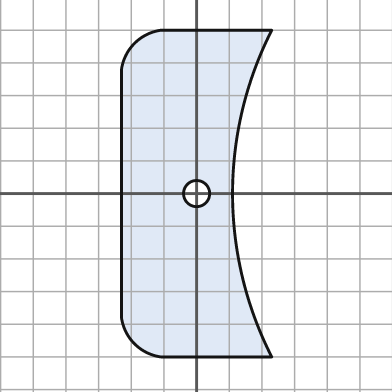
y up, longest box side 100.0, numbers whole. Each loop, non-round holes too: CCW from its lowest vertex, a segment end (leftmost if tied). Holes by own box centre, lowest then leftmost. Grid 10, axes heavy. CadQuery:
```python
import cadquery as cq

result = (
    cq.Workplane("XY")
    .moveTo(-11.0, -50.0)
    .lineTo(23.0, -50.0)
    .threePointArc((11.0, 0.0), (23.0, 50.0))
    .lineTo(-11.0, 50.0)
    .threePointArc((-19.0, 46.0), (-23.0, 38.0))
    .lineTo(-23.0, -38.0)
    .threePointArc((-19.0, -46.0), (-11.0, -50.0))
    .close()
    .moveTo(0.0, 0.0)
    .circle(4.0)
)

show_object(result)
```